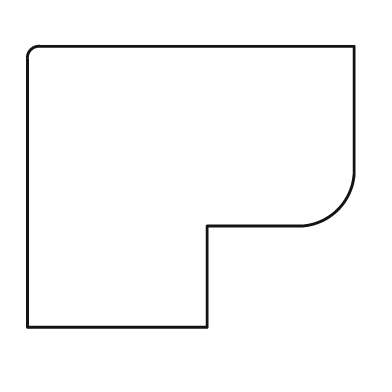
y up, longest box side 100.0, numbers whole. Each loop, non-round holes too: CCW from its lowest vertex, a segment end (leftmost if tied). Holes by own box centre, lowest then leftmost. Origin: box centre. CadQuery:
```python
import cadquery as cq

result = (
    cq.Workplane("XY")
    .moveTo(-50.0, -43.0)
    .lineTo(5.0, -43.0)
    .lineTo(5.0, -12.0)
    .lineTo(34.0, -12.0)
    .threePointArc((45.0, -7.0), (50.0, 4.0))
    .lineTo(50.0, 43.0)
    .lineTo(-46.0, 43.0)
    .threePointArc((-49.0, 42.0), (-50.0, 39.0))
    .close()
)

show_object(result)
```